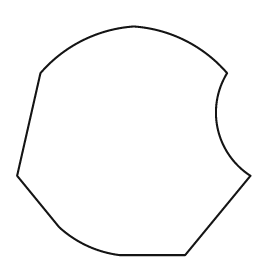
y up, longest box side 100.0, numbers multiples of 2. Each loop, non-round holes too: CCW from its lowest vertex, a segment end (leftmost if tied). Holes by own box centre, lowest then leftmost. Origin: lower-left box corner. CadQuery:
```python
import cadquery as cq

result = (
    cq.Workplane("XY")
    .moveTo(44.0, 0.0)
    .lineTo(72.0, 0.0)
    .lineTo(100.0, 34.0)
    .threePointArc((86.0, 54.0), (90.0, 78.0))
    .threePointArc((72.0, 92.0), (50.0, 98.0))
    .threePointArc((28.0, 92.0), (10.0, 78.0))
    .lineTo(0.0, 34.0)
    .lineTo(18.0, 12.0)
    .threePointArc((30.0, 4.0), (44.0, 0.0))
    .close()
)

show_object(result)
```